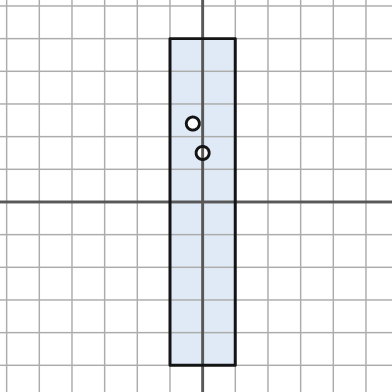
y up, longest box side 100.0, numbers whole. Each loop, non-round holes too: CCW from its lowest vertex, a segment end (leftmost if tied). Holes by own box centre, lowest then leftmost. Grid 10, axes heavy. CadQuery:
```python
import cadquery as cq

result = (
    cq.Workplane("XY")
    .moveTo(-10.0, -50.0)
    .lineTo(10.0, -50.0)
    .lineTo(10.0, 50.0)
    .lineTo(-10.0, 50.0)
    .close()
    .moveTo(0.0, 15.0)
    .circle(2.0)
    .moveTo(-3.0, 24.0)
    .circle(2.0)
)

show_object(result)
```